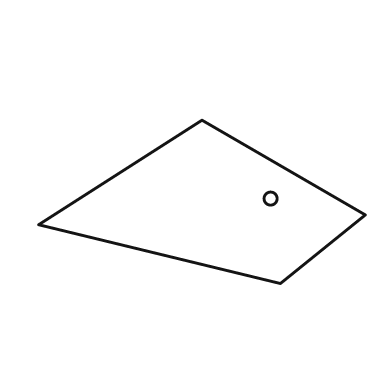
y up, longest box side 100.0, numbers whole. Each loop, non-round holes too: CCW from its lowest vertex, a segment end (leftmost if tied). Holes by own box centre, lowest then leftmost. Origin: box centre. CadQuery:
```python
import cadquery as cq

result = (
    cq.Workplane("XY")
    .moveTo(24.0, -25.0)
    .lineTo(50.0, -4.0)
    .lineTo(0.0, 25.0)
    .lineTo(-50.0, -7.0)
    .close()
    .moveTo(21.0, 1.0)
    .circle(2.0)
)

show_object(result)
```